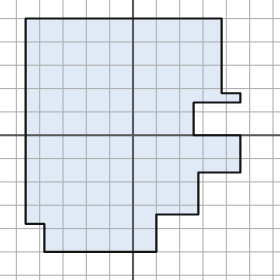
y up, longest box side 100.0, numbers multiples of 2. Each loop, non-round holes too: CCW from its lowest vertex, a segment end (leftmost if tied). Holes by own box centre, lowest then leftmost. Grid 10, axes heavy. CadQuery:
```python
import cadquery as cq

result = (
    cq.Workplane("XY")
    .moveTo(-38.0, -50.0)
    .lineTo(10.0, -50.0)
    .lineTo(10.0, -34.0)
    .lineTo(28.0, -34.0)
    .lineTo(28.0, -16.0)
    .lineTo(46.0, -16.0)
    .lineTo(46.0, 0.0)
    .lineTo(26.0, 0.0)
    .lineTo(26.0, 14.0)
    .lineTo(46.0, 14.0)
    .lineTo(46.0, 18.0)
    .lineTo(38.0, 18.0)
    .lineTo(38.0, 50.0)
    .lineTo(-46.0, 50.0)
    .lineTo(-46.0, -38.0)
    .lineTo(-38.0, -38.0)
    .close()
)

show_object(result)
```